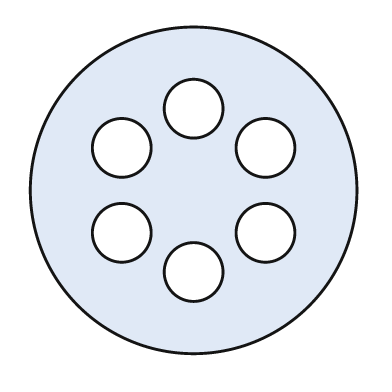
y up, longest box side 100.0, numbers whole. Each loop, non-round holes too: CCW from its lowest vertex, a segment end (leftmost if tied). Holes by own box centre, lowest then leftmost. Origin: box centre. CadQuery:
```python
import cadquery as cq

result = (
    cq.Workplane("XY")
    .moveTo(0.0, 0.0)
    .circle(50.0)
    .moveTo(0.0, -25.0)
    .circle(9.0)
    .moveTo(-22.0, -13.0)
    .circle(9.0)
    .moveTo(22.0, -13.0)
    .circle(9.0)
    .moveTo(-22.0, 13.0)
    .circle(9.0)
    .moveTo(22.0, 13.0)
    .circle(9.0)
    .moveTo(0.0, 25.0)
    .circle(9.0)
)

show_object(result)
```